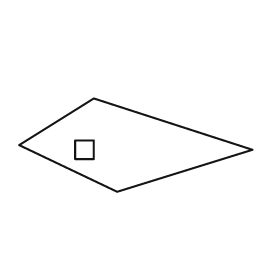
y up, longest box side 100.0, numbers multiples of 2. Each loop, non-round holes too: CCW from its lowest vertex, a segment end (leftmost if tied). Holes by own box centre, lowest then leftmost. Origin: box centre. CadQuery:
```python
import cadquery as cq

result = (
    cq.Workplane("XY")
    .moveTo(-8.0, -20.0)
    .lineTo(50.0, -2.0)
    .lineTo(-18.0, 20.0)
    .lineTo(-50.0, 0.0)
    .close()
    .moveTo(-26.0, -6.0)
    .lineTo(-18.0, -6.0)
    .lineTo(-18.0, 2.0)
    .lineTo(-26.0, 2.0)
    .close()
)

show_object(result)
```